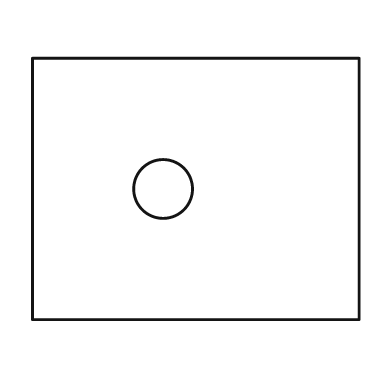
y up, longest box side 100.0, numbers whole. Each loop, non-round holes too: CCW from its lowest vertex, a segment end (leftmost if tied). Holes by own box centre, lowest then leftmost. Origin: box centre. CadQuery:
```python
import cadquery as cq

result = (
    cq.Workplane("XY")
    .moveTo(-50.0, -40.0)
    .lineTo(50.0, -40.0)
    .lineTo(50.0, 40.0)
    .lineTo(-50.0, 40.0)
    .close()
    .moveTo(-10.0, 0.0)
    .circle(9.0)
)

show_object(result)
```